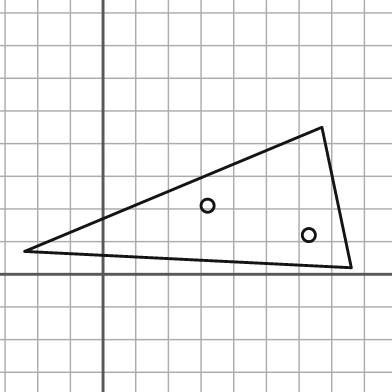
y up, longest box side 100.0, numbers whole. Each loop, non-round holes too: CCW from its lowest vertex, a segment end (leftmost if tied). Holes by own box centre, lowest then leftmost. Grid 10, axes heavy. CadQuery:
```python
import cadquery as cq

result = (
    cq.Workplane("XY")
    .moveTo(76.0, 2.0)
    .lineTo(67.0, 45.0)
    .lineTo(-24.0, 7.0)
    .close()
    .moveTo(63.0, 12.0)
    .circle(2.0)
    .moveTo(32.0, 21.0)
    .circle(2.0)
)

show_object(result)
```